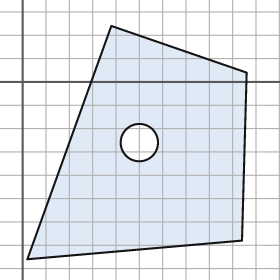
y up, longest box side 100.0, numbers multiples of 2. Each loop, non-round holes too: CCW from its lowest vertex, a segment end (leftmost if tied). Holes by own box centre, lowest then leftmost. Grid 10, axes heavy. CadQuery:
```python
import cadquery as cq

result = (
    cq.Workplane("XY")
    .moveTo(2.0, -76.0)
    .lineTo(94.0, -68.0)
    .lineTo(96.0, 4.0)
    .lineTo(38.0, 24.0)
    .close()
    .moveTo(50.0, -26.0)
    .circle(8.0)
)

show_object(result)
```